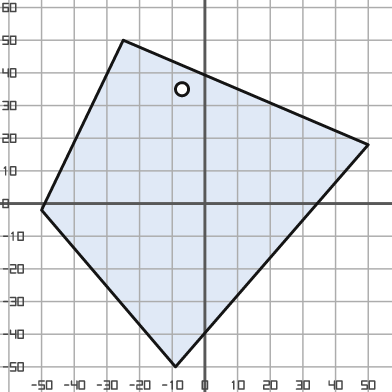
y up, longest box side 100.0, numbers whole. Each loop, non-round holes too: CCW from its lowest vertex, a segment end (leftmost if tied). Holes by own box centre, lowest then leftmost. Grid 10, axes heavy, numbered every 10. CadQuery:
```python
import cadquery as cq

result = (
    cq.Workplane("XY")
    .moveTo(-9.0, -50.0)
    .lineTo(50.0, 18.0)
    .lineTo(-25.0, 50.0)
    .lineTo(-50.0, -2.0)
    .close()
    .moveTo(-7.0, 35.0)
    .circle(2.0)
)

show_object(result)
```